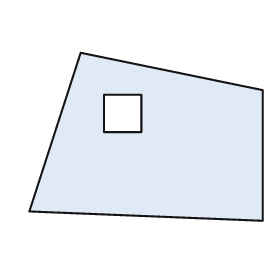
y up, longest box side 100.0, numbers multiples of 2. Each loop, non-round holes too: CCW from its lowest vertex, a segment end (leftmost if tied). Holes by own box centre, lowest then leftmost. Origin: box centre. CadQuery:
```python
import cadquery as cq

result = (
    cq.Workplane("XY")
    .moveTo(50.0, -36.0)
    .lineTo(50.0, 20.0)
    .lineTo(-28.0, 36.0)
    .lineTo(-50.0, -32.0)
    .close()
    .moveTo(-18.0, 2.0)
    .lineTo(-2.0, 2.0)
    .lineTo(-2.0, 18.0)
    .lineTo(-18.0, 18.0)
    .close()
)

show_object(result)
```